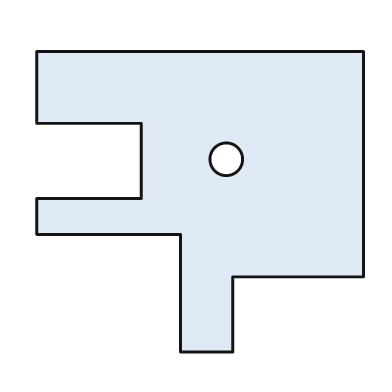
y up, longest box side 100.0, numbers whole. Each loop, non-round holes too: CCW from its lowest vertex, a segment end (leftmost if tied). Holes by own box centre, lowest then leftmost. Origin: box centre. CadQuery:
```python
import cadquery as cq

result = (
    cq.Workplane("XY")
    .moveTo(-6.0, -46.0)
    .lineTo(10.0, -46.0)
    .lineTo(10.0, -23.0)
    .lineTo(50.0, -23.0)
    .lineTo(50.0, 46.0)
    .lineTo(-50.0, 46.0)
    .lineTo(-50.0, 24.0)
    .lineTo(-18.0, 24.0)
    .lineTo(-18.0, 1.0)
    .lineTo(-50.0, 1.0)
    .lineTo(-50.0, -10.0)
    .lineTo(-6.0, -10.0)
    .close()
    .moveTo(8.0, 13.0)
    .circle(5.0)
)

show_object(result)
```